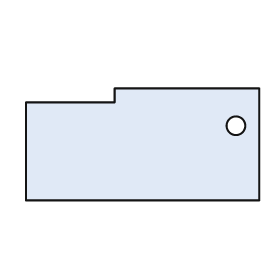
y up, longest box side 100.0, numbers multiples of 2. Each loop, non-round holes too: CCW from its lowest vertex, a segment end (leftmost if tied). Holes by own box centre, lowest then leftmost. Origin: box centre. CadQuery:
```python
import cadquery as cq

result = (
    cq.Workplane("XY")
    .moveTo(-50.0, -24.0)
    .lineTo(50.0, -24.0)
    .lineTo(50.0, 24.0)
    .lineTo(-12.0, 24.0)
    .lineTo(-12.0, 18.0)
    .lineTo(-50.0, 18.0)
    .close()
    .moveTo(40.0, 8.0)
    .circle(4.0)
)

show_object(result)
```